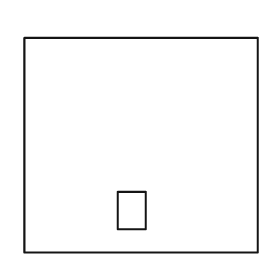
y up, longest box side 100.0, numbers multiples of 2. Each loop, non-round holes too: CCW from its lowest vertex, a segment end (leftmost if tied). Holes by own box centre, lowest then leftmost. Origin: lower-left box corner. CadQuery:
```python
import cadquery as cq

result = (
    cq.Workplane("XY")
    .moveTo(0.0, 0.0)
    .lineTo(100.0, 0.0)
    .lineTo(100.0, 92.0)
    .lineTo(0.0, 92.0)
    .close()
    .moveTo(40.0, 10.0)
    .lineTo(52.0, 10.0)
    .lineTo(52.0, 26.0)
    .lineTo(40.0, 26.0)
    .close()
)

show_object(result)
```